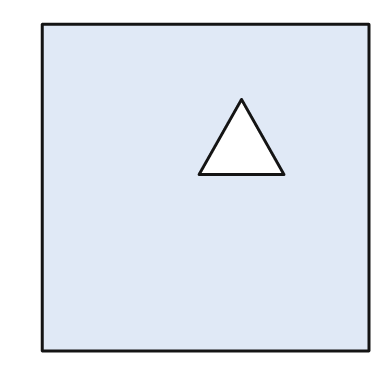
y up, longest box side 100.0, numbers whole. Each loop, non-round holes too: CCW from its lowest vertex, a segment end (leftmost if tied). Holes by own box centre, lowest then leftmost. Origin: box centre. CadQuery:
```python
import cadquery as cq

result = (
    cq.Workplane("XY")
    .moveTo(-50.0, -50.0)
    .lineTo(50.0, -50.0)
    .lineTo(50.0, 50.0)
    .lineTo(-50.0, 50.0)
    .close()
    .moveTo(-2.0, 4.0)
    .lineTo(24.0, 4.0)
    .lineTo(11.0, 27.0)
    .close()
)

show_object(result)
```